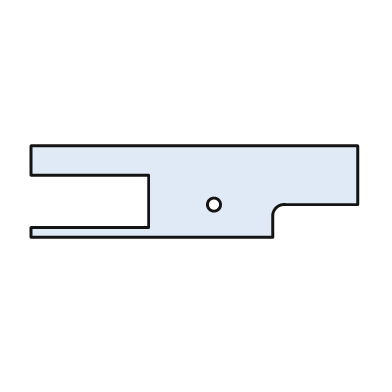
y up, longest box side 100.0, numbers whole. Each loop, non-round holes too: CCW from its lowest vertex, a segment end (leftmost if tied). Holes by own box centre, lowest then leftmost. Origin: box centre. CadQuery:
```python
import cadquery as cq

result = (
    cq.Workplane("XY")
    .moveTo(-50.0, -14.0)
    .lineTo(24.0, -14.0)
    .lineTo(24.0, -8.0)
    .threePointArc((25.0, -5.0), (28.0, -4.0))
    .lineTo(50.0, -4.0)
    .lineTo(50.0, 14.0)
    .lineTo(-50.0, 14.0)
    .lineTo(-50.0, 5.0)
    .lineTo(-14.0, 5.0)
    .lineTo(-14.0, -11.0)
    .lineTo(-50.0, -11.0)
    .close()
    .moveTo(6.0, -4.0)
    .circle(2.0)
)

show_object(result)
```